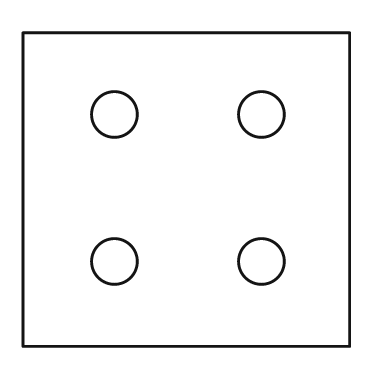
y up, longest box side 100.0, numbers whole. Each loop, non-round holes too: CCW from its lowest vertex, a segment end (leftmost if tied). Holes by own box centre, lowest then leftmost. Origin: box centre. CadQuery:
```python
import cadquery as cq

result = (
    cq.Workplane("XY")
    .moveTo(-50.0, -48.0)
    .lineTo(50.0, -48.0)
    .lineTo(50.0, 48.0)
    .lineTo(-50.0, 48.0)
    .close()
    .moveTo(-22.0, -22.0)
    .circle(7.0)
    .moveTo(23.0, -22.0)
    .circle(7.0)
    .moveTo(-22.0, 23.0)
    .circle(7.0)
    .moveTo(23.0, 23.0)
    .circle(7.0)
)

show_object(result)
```